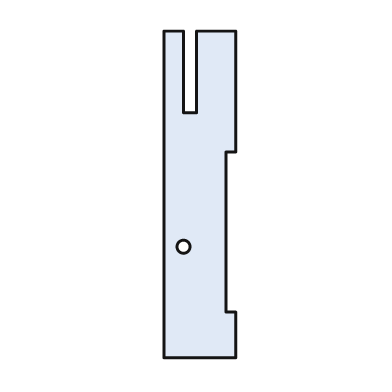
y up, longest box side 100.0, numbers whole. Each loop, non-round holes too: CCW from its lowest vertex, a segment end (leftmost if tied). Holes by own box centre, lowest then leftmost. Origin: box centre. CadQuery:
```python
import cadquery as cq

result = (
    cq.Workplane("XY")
    .moveTo(-11.0, -50.0)
    .lineTo(11.0, -50.0)
    .lineTo(11.0, -36.0)
    .lineTo(8.0, -36.0)
    .lineTo(8.0, 13.0)
    .lineTo(11.0, 13.0)
    .lineTo(11.0, 50.0)
    .lineTo(-1.0, 50.0)
    .lineTo(-1.0, 25.0)
    .lineTo(-5.0, 25.0)
    .lineTo(-5.0, 50.0)
    .lineTo(-11.0, 50.0)
    .close()
    .moveTo(-5.0, -16.0)
    .circle(2.0)
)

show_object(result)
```